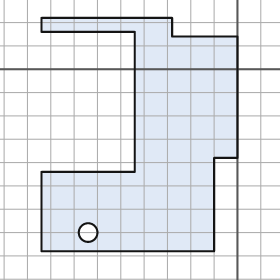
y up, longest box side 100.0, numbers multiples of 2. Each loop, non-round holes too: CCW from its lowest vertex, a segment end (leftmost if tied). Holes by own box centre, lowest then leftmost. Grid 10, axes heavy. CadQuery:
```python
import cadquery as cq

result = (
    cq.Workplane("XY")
    .moveTo(-84.0, -78.0)
    .lineTo(-10.0, -78.0)
    .lineTo(-10.0, -38.0)
    .lineTo(0.0, -38.0)
    .lineTo(0.0, 14.0)
    .lineTo(-28.0, 14.0)
    .lineTo(-28.0, 22.0)
    .lineTo(-84.0, 22.0)
    .lineTo(-84.0, 16.0)
    .lineTo(-44.0, 16.0)
    .lineTo(-44.0, -44.0)
    .lineTo(-84.0, -44.0)
    .close()
    .moveTo(-64.0, -70.0)
    .circle(4.0)
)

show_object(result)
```